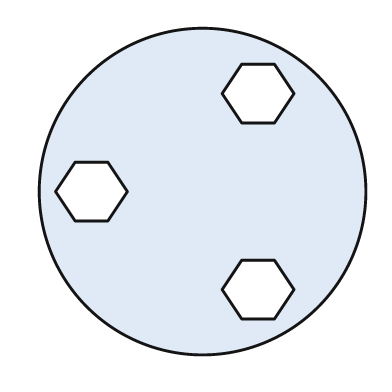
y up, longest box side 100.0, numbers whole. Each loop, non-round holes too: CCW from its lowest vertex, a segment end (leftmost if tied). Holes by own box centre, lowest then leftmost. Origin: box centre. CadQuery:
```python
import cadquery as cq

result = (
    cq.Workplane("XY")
    .moveTo(0.0, 0.0)
    .circle(50.0)
    .moveTo(12.0, -39.0)
    .lineTo(22.0, -39.0)
    .lineTo(28.0, -30.0)
    .lineTo(22.0, -21.0)
    .lineTo(12.0, -21.0)
    .lineTo(6.0, -30.0)
    .close()
    .moveTo(-39.0, -9.0)
    .lineTo(-29.0, -9.0)
    .lineTo(-23.0, 0.0)
    .lineTo(-29.0, 9.0)
    .lineTo(-39.0, 9.0)
    .lineTo(-45.0, 0.0)
    .close()
    .moveTo(12.0, 21.0)
    .lineTo(22.0, 21.0)
    .lineTo(28.0, 30.0)
    .lineTo(22.0, 39.0)
    .lineTo(12.0, 39.0)
    .lineTo(6.0, 30.0)
    .close()
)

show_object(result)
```